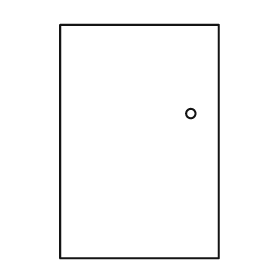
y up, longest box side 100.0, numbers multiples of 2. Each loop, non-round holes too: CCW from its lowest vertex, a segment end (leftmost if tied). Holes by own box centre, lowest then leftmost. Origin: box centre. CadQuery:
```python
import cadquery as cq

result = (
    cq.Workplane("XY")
    .moveTo(-34.0, -50.0)
    .lineTo(34.0, -50.0)
    .lineTo(34.0, 50.0)
    .lineTo(-34.0, 50.0)
    .close()
    .moveTo(22.0, 12.0)
    .circle(2.0)
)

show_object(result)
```